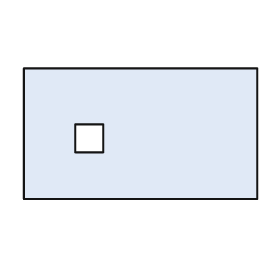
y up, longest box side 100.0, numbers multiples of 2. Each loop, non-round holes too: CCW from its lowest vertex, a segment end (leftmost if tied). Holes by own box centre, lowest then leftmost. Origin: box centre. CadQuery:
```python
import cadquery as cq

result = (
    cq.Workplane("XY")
    .moveTo(-50.0, -28.0)
    .lineTo(50.0, -28.0)
    .lineTo(50.0, 28.0)
    .lineTo(-50.0, 28.0)
    .close()
    .moveTo(-28.0, -8.0)
    .lineTo(-16.0, -8.0)
    .lineTo(-16.0, 4.0)
    .lineTo(-28.0, 4.0)
    .close()
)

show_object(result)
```